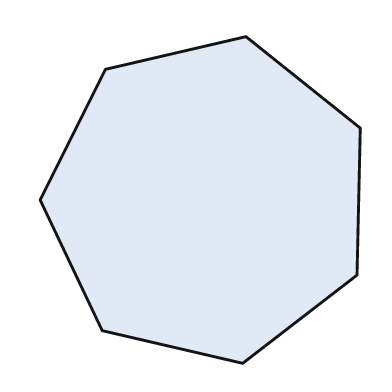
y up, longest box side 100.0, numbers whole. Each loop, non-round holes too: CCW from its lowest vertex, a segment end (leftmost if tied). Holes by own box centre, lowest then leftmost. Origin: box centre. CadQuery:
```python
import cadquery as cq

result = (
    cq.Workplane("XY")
    .moveTo(13.0, -50.0)
    .lineTo(48.0, -23.0)
    .lineTo(49.0, 22.0)
    .lineTo(14.0, 50.0)
    .lineTo(-29.0, 40.0)
    .lineTo(-49.0, 0.0)
    .lineTo(-30.0, -40.0)
    .close()
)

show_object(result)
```